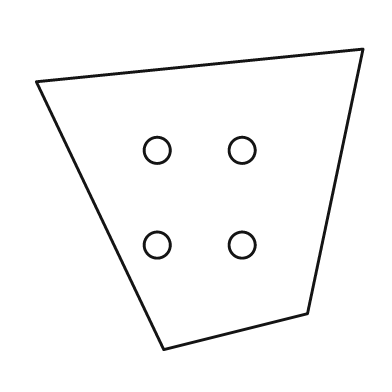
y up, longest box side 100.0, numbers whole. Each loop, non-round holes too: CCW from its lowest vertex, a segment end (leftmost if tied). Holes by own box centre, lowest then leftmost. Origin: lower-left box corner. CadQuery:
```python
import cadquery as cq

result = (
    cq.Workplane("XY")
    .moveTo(39.0, 0.0)
    .lineTo(83.0, 11.0)
    .lineTo(100.0, 92.0)
    .lineTo(0.0, 82.0)
    .close()
    .moveTo(37.0, 32.0)
    .circle(4.0)
    .moveTo(63.0, 32.0)
    .circle(4.0)
    .moveTo(37.0, 61.0)
    .circle(4.0)
    .moveTo(63.0, 61.0)
    .circle(4.0)
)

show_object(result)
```